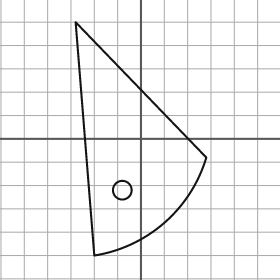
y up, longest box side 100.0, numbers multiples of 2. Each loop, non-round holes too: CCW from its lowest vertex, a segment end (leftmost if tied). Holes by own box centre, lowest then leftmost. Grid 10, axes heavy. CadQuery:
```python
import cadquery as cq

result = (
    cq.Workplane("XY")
    .moveTo(-20.0, -50.0)
    .threePointArc((10.0, -36.0), (28.0, -8.0))
    .lineTo(-28.0, 50.0)
    .close()
    .moveTo(-8.0, -22.0)
    .circle(4.0)
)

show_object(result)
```